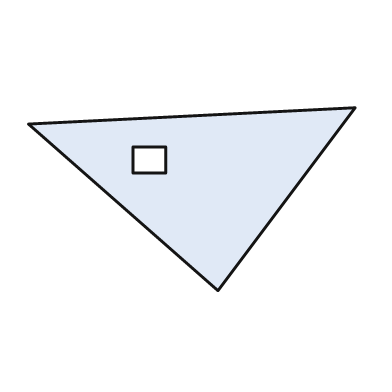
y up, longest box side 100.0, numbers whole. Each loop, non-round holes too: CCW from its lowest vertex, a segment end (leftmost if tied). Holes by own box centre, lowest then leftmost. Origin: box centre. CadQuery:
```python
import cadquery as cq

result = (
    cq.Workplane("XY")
    .moveTo(8.0, -28.0)
    .lineTo(50.0, 28.0)
    .lineTo(-50.0, 23.0)
    .close()
    .moveTo(-18.0, 8.0)
    .lineTo(-8.0, 8.0)
    .lineTo(-8.0, 16.0)
    .lineTo(-18.0, 16.0)
    .close()
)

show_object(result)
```